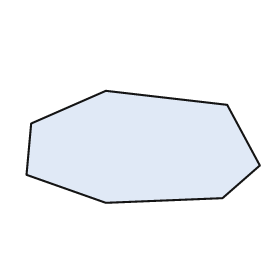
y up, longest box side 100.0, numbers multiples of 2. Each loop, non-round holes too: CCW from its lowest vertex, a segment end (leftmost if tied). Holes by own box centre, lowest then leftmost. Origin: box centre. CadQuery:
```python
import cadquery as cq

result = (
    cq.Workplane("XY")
    .moveTo(-16.0, -24.0)
    .lineTo(34.0, -22.0)
    .lineTo(50.0, -8.0)
    .lineTo(36.0, 18.0)
    .lineTo(-16.0, 24.0)
    .lineTo(-48.0, 10.0)
    .lineTo(-50.0, -12.0)
    .close()
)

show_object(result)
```